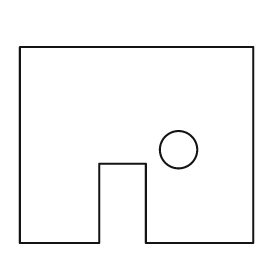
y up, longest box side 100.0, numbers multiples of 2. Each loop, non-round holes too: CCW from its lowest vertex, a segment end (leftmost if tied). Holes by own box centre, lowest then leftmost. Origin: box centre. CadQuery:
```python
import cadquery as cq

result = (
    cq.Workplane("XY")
    .moveTo(-50.0, -42.0)
    .lineTo(-16.0, -42.0)
    .lineTo(-16.0, -8.0)
    .lineTo(4.0, -8.0)
    .lineTo(4.0, -42.0)
    .lineTo(50.0, -42.0)
    .lineTo(50.0, 42.0)
    .lineTo(-50.0, 42.0)
    .close()
    .moveTo(18.0, -2.0)
    .circle(8.0)
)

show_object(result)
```